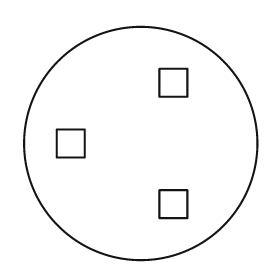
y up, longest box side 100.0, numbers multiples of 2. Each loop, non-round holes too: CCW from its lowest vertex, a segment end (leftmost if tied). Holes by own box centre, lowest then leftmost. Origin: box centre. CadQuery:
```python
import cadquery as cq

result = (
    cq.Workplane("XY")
    .moveTo(0.0, 0.0)
    .circle(50.0)
    .moveTo(8.0, -32.0)
    .lineTo(20.0, -32.0)
    .lineTo(20.0, -20.0)
    .lineTo(8.0, -20.0)
    .close()
    .moveTo(-36.0, -6.0)
    .lineTo(-24.0, -6.0)
    .lineTo(-24.0, 6.0)
    .lineTo(-36.0, 6.0)
    .close()
    .moveTo(8.0, 20.0)
    .lineTo(20.0, 20.0)
    .lineTo(20.0, 32.0)
    .lineTo(8.0, 32.0)
    .close()
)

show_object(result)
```